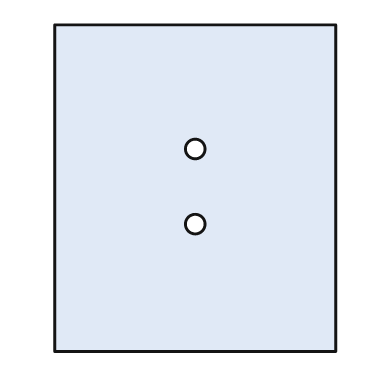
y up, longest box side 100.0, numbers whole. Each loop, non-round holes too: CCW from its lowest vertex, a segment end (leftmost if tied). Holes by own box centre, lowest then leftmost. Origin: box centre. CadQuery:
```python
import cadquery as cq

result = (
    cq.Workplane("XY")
    .moveTo(-43.0, -50.0)
    .lineTo(43.0, -50.0)
    .lineTo(43.0, 50.0)
    .lineTo(-43.0, 50.0)
    .close()
    .moveTo(0.0, -11.0)
    .circle(3.0)
    .moveTo(0.0, 12.0)
    .circle(3.0)
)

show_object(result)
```